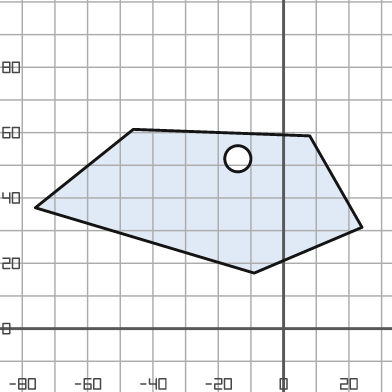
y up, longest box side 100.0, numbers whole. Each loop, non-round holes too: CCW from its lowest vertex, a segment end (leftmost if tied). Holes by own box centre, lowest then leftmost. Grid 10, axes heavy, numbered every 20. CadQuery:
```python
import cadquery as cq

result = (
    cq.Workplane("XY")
    .moveTo(-9.0, 17.0)
    .lineTo(24.0, 31.0)
    .lineTo(8.0, 59.0)
    .lineTo(-46.0, 61.0)
    .lineTo(-76.0, 37.0)
    .close()
    .moveTo(-14.0, 52.0)
    .circle(4.0)
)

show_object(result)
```